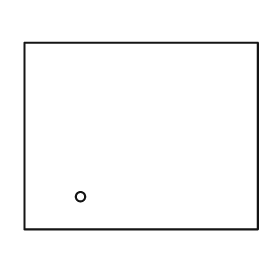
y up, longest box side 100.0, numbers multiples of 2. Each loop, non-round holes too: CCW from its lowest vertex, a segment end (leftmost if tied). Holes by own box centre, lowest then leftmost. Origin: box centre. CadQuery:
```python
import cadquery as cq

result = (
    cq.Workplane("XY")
    .moveTo(-50.0, -40.0)
    .lineTo(50.0, -40.0)
    .lineTo(50.0, 40.0)
    .lineTo(-50.0, 40.0)
    .close()
    .moveTo(-26.0, -26.0)
    .circle(2.0)
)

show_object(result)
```